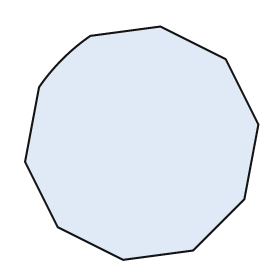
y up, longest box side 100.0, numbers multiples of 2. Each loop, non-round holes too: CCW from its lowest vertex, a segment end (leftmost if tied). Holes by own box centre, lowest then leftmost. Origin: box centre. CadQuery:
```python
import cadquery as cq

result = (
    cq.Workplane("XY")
    .moveTo(-8.0, -50.0)
    .lineTo(22.0, -46.0)
    .lineTo(44.0, -24.0)
    .lineTo(50.0, 8.0)
    .lineTo(36.0, 36.0)
    .lineTo(8.0, 50.0)
    .lineTo(-22.0, 46.0)
    .threePointArc((-34.0, 36.0), (-44.0, 24.0))
    .lineTo(-50.0, -8.0)
    .lineTo(-36.0, -36.0)
    .close()
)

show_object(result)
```